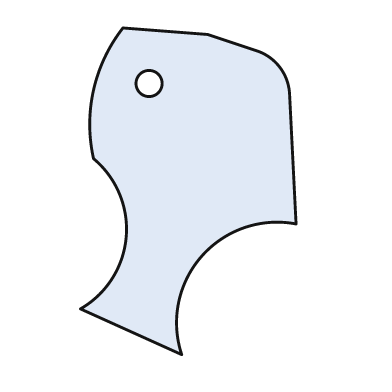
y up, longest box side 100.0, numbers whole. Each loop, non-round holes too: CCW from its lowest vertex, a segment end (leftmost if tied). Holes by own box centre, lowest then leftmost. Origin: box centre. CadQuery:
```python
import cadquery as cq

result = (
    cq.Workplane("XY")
    .moveTo(-2.0, -50.0)
    .threePointArc((4.0, -20.0), (33.0, -10.0))
    .lineTo(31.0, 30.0)
    .threePointArc((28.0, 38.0), (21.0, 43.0))
    .lineTo(6.0, 48.0)
    .lineTo(-20.0, 50.0)
    .threePointArc((-29.0, 31.0), (-29.0, 10.0))
    .threePointArc((-19.0, -14.0), (-33.0, -36.0))
    .close()
    .moveTo(-12.0, 33.0)
    .circle(4.0)
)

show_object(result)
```